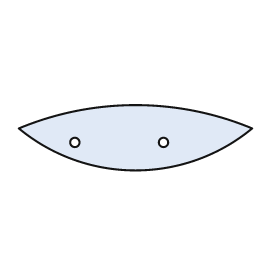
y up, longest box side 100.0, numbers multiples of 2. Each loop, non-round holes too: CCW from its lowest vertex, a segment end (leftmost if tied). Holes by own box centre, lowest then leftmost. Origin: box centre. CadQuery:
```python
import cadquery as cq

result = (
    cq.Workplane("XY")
    .moveTo(-50.0, 4.0)
    .threePointArc((0.0, -14.0), (50.0, 4.0))
    .threePointArc((0.0, 14.0), (-50.0, 4.0))
    .close()
    .moveTo(-26.0, -2.0)
    .circle(2.0)
    .moveTo(12.0, -2.0)
    .circle(2.0)
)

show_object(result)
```